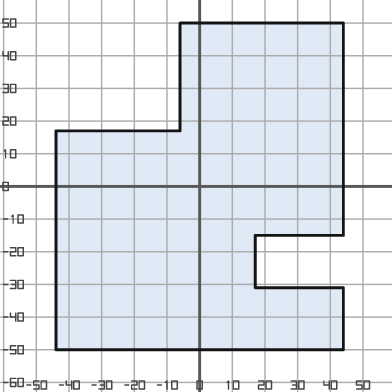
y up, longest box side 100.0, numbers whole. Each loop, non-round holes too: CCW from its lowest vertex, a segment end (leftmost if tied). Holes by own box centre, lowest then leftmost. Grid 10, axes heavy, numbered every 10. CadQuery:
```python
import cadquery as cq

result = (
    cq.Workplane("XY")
    .moveTo(-44.0, -50.0)
    .lineTo(44.0, -50.0)
    .lineTo(44.0, -31.0)
    .lineTo(17.0, -31.0)
    .lineTo(17.0, -15.0)
    .lineTo(44.0, -15.0)
    .lineTo(44.0, 50.0)
    .lineTo(-6.0, 50.0)
    .lineTo(-6.0, 17.0)
    .lineTo(-44.0, 17.0)
    .close()
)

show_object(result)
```